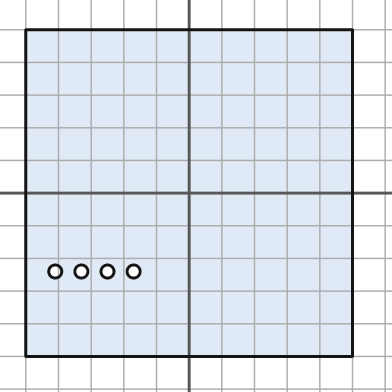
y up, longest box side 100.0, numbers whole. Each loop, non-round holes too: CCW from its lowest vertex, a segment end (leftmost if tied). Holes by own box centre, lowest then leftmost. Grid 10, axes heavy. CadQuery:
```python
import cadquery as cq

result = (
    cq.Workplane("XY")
    .moveTo(-50.0, -50.0)
    .lineTo(50.0, -50.0)
    .lineTo(50.0, 50.0)
    .lineTo(-50.0, 50.0)
    .close()
    .moveTo(-41.0, -24.0)
    .circle(2.0)
    .moveTo(-33.0, -24.0)
    .circle(2.0)
    .moveTo(-25.0, -24.0)
    .circle(2.0)
    .moveTo(-17.0, -24.0)
    .circle(2.0)
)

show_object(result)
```